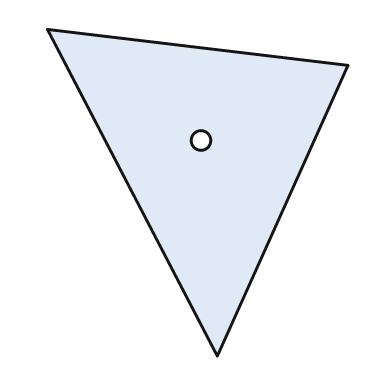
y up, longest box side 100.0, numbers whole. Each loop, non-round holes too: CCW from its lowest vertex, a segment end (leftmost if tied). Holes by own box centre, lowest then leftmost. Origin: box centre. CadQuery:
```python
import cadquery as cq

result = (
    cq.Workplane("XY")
    .moveTo(6.0, -50.0)
    .lineTo(46.0, 39.0)
    .lineTo(-46.0, 50.0)
    .close()
    .moveTo(1.0, 16.0)
    .circle(3.0)
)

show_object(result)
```